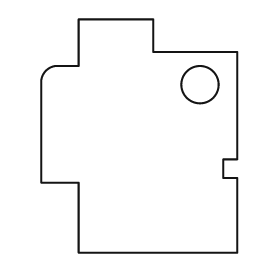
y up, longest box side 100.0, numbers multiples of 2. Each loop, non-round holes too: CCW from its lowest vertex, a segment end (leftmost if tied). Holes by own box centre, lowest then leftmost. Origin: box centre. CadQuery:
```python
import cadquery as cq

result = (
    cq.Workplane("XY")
    .moveTo(-26.0, -50.0)
    .lineTo(42.0, -50.0)
    .lineTo(42.0, -18.0)
    .lineTo(36.0, -18.0)
    .lineTo(36.0, -10.0)
    .lineTo(42.0, -10.0)
    .lineTo(42.0, 36.0)
    .lineTo(6.0, 36.0)
    .lineTo(6.0, 50.0)
    .lineTo(-26.0, 50.0)
    .lineTo(-26.0, 30.0)
    .lineTo(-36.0, 30.0)
    .threePointArc((-40.0, 28.0), (-42.0, 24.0))
    .lineTo(-42.0, -20.0)
    .lineTo(-26.0, -20.0)
    .close()
    .moveTo(26.0, 22.0)
    .circle(8.0)
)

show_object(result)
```